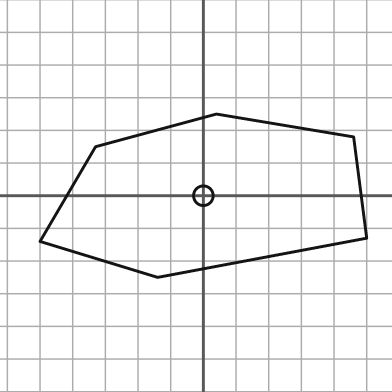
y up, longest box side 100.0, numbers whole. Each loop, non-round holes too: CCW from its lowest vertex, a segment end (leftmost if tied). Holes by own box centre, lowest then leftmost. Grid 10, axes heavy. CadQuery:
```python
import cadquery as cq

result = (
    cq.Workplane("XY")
    .moveTo(-14.0, -25.0)
    .lineTo(50.0, -13.0)
    .lineTo(46.0, 18.0)
    .lineTo(4.0, 25.0)
    .lineTo(-33.0, 15.0)
    .lineTo(-50.0, -14.0)
    .close()
    .moveTo(0.0, 0.0)
    .circle(3.0)
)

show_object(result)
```